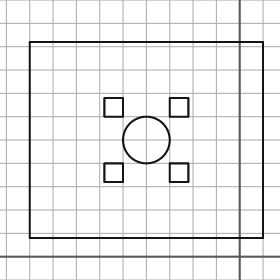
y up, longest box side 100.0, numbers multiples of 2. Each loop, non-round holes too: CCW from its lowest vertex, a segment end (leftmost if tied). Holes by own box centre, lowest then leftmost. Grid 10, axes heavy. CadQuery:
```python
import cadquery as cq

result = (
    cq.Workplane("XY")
    .moveTo(-90.0, 8.0)
    .lineTo(10.0, 8.0)
    .lineTo(10.0, 92.0)
    .lineTo(-90.0, 92.0)
    .close()
    .moveTo(-58.0, 32.0)
    .lineTo(-50.0, 32.0)
    .lineTo(-50.0, 40.0)
    .lineTo(-58.0, 40.0)
    .close()
    .moveTo(-30.0, 32.0)
    .lineTo(-22.0, 32.0)
    .lineTo(-22.0, 40.0)
    .lineTo(-30.0, 40.0)
    .close()
    .moveTo(-40.0, 50.0)
    .circle(10.0)
    .moveTo(-58.0, 60.0)
    .lineTo(-50.0, 60.0)
    .lineTo(-50.0, 68.0)
    .lineTo(-58.0, 68.0)
    .close()
    .moveTo(-30.0, 60.0)
    .lineTo(-22.0, 60.0)
    .lineTo(-22.0, 68.0)
    .lineTo(-30.0, 68.0)
    .close()
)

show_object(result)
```